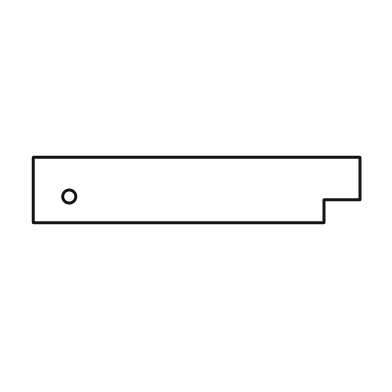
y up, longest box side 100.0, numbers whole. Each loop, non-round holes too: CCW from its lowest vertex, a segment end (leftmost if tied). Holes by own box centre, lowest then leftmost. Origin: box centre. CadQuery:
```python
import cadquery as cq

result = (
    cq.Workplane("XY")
    .moveTo(-50.0, -10.0)
    .lineTo(39.0, -10.0)
    .lineTo(39.0, -3.0)
    .lineTo(50.0, -3.0)
    .lineTo(50.0, 10.0)
    .lineTo(-50.0, 10.0)
    .close()
    .moveTo(-39.0, -2.0)
    .circle(2.0)
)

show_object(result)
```